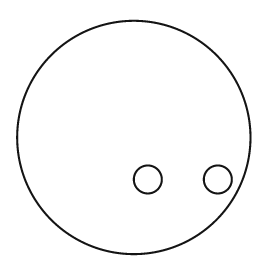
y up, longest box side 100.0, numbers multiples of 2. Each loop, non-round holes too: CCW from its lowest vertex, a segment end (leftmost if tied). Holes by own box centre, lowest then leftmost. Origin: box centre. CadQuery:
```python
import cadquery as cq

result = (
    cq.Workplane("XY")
    .moveTo(0.0, 0.0)
    .circle(50.0)
    .moveTo(6.0, -18.0)
    .circle(6.0)
    .moveTo(36.0, -18.0)
    .circle(6.0)
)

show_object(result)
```